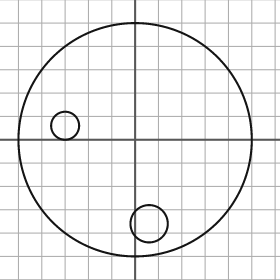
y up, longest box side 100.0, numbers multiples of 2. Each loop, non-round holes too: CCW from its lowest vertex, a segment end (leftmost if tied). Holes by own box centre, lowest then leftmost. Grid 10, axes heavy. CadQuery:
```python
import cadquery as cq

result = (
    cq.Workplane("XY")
    .moveTo(0.0, 0.0)
    .circle(50.0)
    .moveTo(6.0, -36.0)
    .circle(8.0)
    .moveTo(-30.0, 6.0)
    .circle(6.0)
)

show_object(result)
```